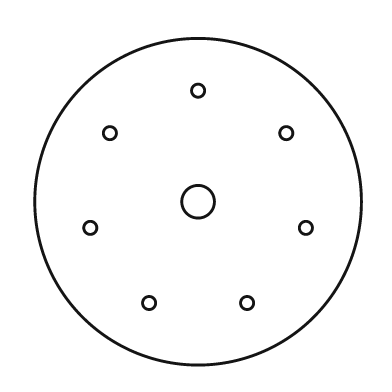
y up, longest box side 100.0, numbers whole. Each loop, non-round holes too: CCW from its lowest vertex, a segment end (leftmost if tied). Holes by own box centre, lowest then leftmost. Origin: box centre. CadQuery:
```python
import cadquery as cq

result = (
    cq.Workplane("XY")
    .moveTo(0.0, 0.0)
    .circle(50.0)
    .moveTo(-15.0, -31.0)
    .circle(2.0)
    .moveTo(15.0, -31.0)
    .circle(2.0)
    .moveTo(-33.0, -8.0)
    .circle(2.0)
    .moveTo(33.0, -8.0)
    .circle(2.0)
    .moveTo(0.0, 0.0)
    .circle(5.0)
    .moveTo(-27.0, 21.0)
    .circle(2.0)
    .moveTo(27.0, 21.0)
    .circle(2.0)
    .moveTo(0.0, 34.0)
    .circle(2.0)
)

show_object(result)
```